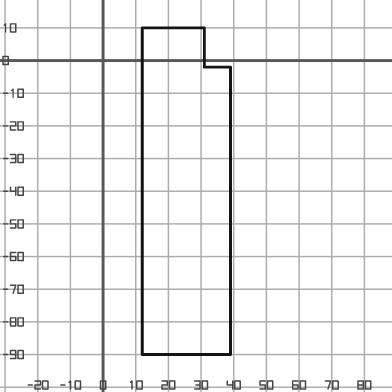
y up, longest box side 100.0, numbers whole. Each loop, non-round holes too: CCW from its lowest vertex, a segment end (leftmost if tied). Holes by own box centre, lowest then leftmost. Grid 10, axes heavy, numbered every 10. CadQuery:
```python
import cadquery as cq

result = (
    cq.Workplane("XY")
    .moveTo(12.0, -90.0)
    .lineTo(39.0, -90.0)
    .lineTo(39.0, -2.0)
    .lineTo(31.0, -2.0)
    .lineTo(31.0, 10.0)
    .lineTo(12.0, 10.0)
    .close()
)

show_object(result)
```